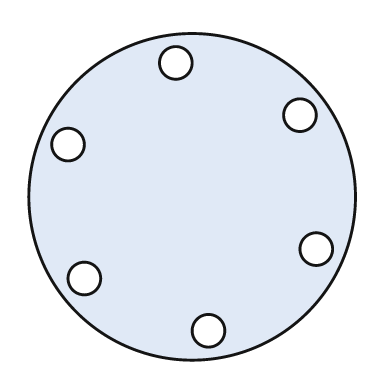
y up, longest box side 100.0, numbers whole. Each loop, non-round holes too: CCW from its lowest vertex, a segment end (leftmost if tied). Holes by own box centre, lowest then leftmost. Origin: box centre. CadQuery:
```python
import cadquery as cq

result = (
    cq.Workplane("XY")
    .moveTo(0.0, 0.0)
    .circle(50.0)
    .moveTo(5.0, -41.0)
    .circle(5.0)
    .moveTo(-33.0, -25.0)
    .circle(5.0)
    .moveTo(38.0, -16.0)
    .circle(5.0)
    .moveTo(-38.0, 16.0)
    .circle(5.0)
    .moveTo(33.0, 25.0)
    .circle(5.0)
    .moveTo(-5.0, 41.0)
    .circle(5.0)
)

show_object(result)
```